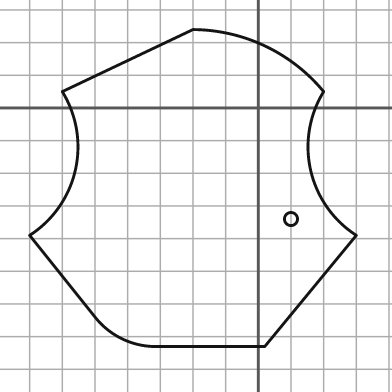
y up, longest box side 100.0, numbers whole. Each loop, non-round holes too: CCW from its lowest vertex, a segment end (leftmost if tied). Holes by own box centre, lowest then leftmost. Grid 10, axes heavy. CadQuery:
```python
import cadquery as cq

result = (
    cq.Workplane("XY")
    .moveTo(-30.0, -73.0)
    .lineTo(2.0, -73.0)
    .lineTo(30.0, -39.0)
    .threePointArc((16.0, -19.0), (20.0, 5.0))
    .threePointArc((2.0, 19.0), (-20.0, 24.0))
    .lineTo(-60.0, 5.0)
    .threePointArc((-56.0, -19.0), (-70.0, -39.0))
    .lineTo(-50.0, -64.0)
    .threePointArc((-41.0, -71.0), (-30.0, -73.0))
    .close()
    .moveTo(10.0, -34.0)
    .circle(2.0)
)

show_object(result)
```